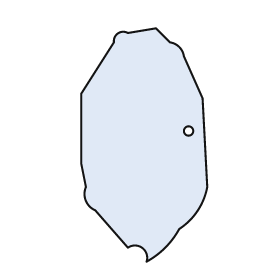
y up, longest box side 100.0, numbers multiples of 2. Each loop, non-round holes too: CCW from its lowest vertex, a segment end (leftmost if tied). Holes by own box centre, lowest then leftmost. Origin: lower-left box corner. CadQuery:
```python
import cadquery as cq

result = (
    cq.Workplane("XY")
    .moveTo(28.0, 0.0)
    .threePointArc((36.0, 6.0), (42.0, 14.0))
    .threePointArc((50.0, 22.0), (54.0, 32.0))
    .lineTo(52.0, 70.0)
    .lineTo(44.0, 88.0)
    .threePointArc((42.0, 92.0), (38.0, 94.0))
    .lineTo(32.0, 100.0)
    .lineTo(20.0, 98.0)
    .threePointArc((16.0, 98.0), (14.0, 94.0))
    .lineTo(0.0, 72.0)
    .lineTo(0.0, 42.0)
    .lineTo(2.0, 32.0)
    .threePointArc((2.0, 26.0), (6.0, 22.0))
    .lineTo(20.0, 6.0)
    .threePointArc((26.0, 6.0), (28.0, 0.0))
    .close()
    .moveTo(46.0, 56.0)
    .circle(2.0)
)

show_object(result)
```